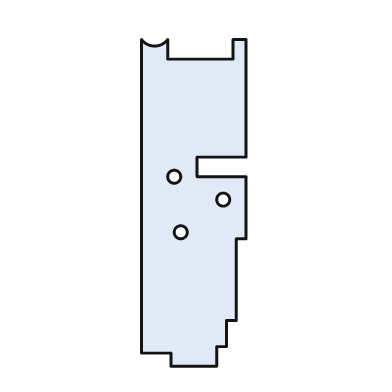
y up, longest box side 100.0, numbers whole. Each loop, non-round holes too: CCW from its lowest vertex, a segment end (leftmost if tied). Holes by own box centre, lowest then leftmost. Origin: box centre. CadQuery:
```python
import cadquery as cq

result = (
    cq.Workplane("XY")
    .moveTo(-7.0, -50.0)
    .lineTo(7.0, -50.0)
    .lineTo(7.0, -44.0)
    .lineTo(10.0, -44.0)
    .lineTo(10.0, -36.0)
    .lineTo(13.0, -36.0)
    .lineTo(13.0, -11.0)
    .lineTo(16.0, -11.0)
    .lineTo(16.0, 8.0)
    .lineTo(1.0, 8.0)
    .lineTo(1.0, 14.0)
    .lineTo(16.0, 14.0)
    .lineTo(16.0, 50.0)
    .lineTo(12.0, 50.0)
    .lineTo(12.0, 44.0)
    .lineTo(-8.0, 44.0)
    .lineTo(-8.0, 50.0)
    .threePointArc((-12.0, 48.0), (-16.0, 50.0))
    .lineTo(-16.0, -46.0)
    .lineTo(-7.0, -46.0)
    .close()
    .moveTo(-4.0, -9.0)
    .circle(2.0)
    .moveTo(9.0, 1.0)
    .circle(2.0)
    .moveTo(-6.0, 8.0)
    .circle(2.0)
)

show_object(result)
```